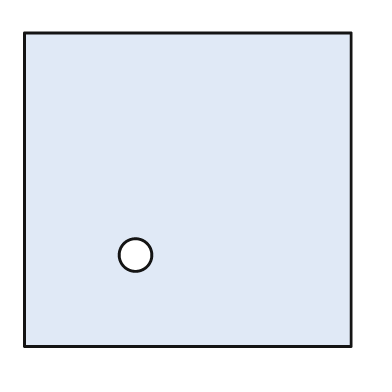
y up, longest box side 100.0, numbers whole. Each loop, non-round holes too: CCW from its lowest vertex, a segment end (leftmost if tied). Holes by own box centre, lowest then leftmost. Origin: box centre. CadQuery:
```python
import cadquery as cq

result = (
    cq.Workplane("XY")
    .moveTo(-50.0, -48.0)
    .lineTo(50.0, -48.0)
    .lineTo(50.0, 48.0)
    .lineTo(-50.0, 48.0)
    .close()
    .moveTo(-16.0, -20.0)
    .circle(5.0)
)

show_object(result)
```